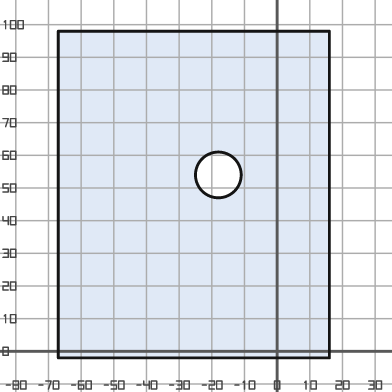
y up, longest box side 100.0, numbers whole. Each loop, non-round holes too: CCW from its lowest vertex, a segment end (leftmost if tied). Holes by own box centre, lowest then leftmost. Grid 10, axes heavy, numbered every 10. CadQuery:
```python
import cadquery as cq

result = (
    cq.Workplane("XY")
    .moveTo(-67.0, -2.0)
    .lineTo(16.0, -2.0)
    .lineTo(16.0, 98.0)
    .lineTo(-67.0, 98.0)
    .close()
    .moveTo(-18.0, 54.0)
    .circle(7.0)
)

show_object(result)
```